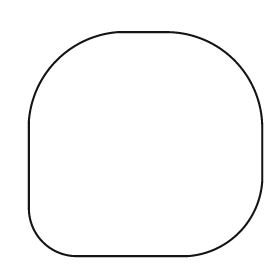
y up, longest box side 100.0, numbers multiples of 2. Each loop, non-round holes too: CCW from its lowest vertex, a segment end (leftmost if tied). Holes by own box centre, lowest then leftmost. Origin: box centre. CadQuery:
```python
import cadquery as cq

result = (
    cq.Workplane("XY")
    .moveTo(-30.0, -48.0)
    .lineTo(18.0, -48.0)
    .threePointArc((40.0, -38.0), (50.0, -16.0))
    .lineTo(50.0, 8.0)
    .threePointArc((38.0, 36.0), (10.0, 48.0))
    .lineTo(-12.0, 48.0)
    .threePointArc((-38.0, 36.0), (-50.0, 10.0))
    .lineTo(-50.0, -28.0)
    .threePointArc((-44.0, -42.0), (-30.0, -48.0))
    .close()
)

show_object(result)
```